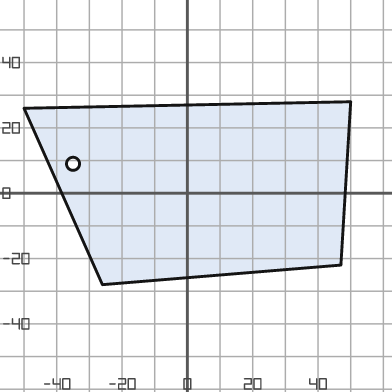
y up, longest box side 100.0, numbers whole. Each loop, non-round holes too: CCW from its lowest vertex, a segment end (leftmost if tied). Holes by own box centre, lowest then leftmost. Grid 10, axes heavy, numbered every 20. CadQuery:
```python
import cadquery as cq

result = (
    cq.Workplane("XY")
    .moveTo(-26.0, -28.0)
    .lineTo(47.0, -22.0)
    .lineTo(50.0, 28.0)
    .lineTo(-50.0, 26.0)
    .close()
    .moveTo(-35.0, 9.0)
    .circle(2.0)
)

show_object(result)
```